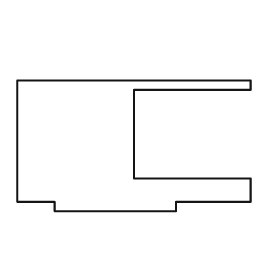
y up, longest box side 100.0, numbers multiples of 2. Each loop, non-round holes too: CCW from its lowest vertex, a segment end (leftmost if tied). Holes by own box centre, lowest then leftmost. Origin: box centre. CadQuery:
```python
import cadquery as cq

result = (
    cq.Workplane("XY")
    .moveTo(-34.0, -28.0)
    .lineTo(18.0, -28.0)
    .lineTo(18.0, -24.0)
    .lineTo(50.0, -24.0)
    .lineTo(50.0, -14.0)
    .lineTo(0.0, -14.0)
    .lineTo(0.0, 24.0)
    .lineTo(50.0, 24.0)
    .lineTo(50.0, 28.0)
    .lineTo(-50.0, 28.0)
    .lineTo(-50.0, -24.0)
    .lineTo(-34.0, -24.0)
    .close()
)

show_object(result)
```